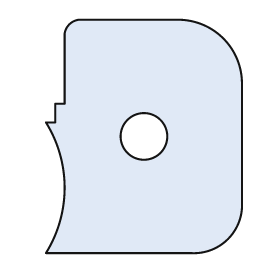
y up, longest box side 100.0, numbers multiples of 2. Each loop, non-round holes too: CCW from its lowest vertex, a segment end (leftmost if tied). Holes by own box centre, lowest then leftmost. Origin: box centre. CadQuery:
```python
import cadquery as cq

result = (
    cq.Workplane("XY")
    .moveTo(-42.0, -50.0)
    .lineTo(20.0, -50.0)
    .threePointArc((36.0, -44.0), (42.0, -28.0))
    .lineTo(42.0, 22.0)
    .threePointArc((34.0, 42.0), (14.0, 50.0))
    .lineTo(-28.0, 50.0)
    .threePointArc((-32.0, 48.0), (-34.0, 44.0))
    .lineTo(-34.0, 14.0)
    .lineTo(-38.0, 14.0)
    .lineTo(-38.0, 6.0)
    .lineTo(-42.0, 6.0)
    .threePointArc((-34.0, -22.0), (-42.0, -50.0))
    .close()
    .moveTo(0.0, 0.0)
    .circle(10.0)
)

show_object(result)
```